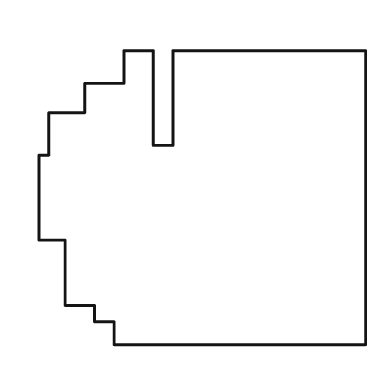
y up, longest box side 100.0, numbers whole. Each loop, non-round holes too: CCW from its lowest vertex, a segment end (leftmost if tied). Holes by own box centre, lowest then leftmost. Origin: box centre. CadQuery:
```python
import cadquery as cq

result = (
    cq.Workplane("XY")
    .moveTo(-27.0, -45.0)
    .lineTo(50.0, -45.0)
    .lineTo(50.0, 45.0)
    .lineTo(-9.0, 45.0)
    .lineTo(-9.0, 16.0)
    .lineTo(-15.0, 16.0)
    .lineTo(-15.0, 45.0)
    .lineTo(-24.0, 45.0)
    .lineTo(-24.0, 35.0)
    .lineTo(-36.0, 35.0)
    .lineTo(-36.0, 26.0)
    .lineTo(-47.0, 26.0)
    .lineTo(-47.0, 13.0)
    .lineTo(-50.0, 13.0)
    .lineTo(-50.0, -13.0)
    .lineTo(-42.0, -13.0)
    .lineTo(-42.0, -33.0)
    .lineTo(-33.0, -33.0)
    .lineTo(-33.0, -38.0)
    .lineTo(-27.0, -38.0)
    .close()
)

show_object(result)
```